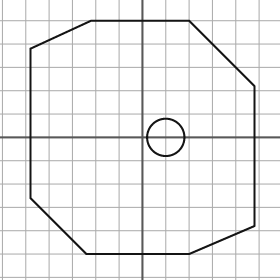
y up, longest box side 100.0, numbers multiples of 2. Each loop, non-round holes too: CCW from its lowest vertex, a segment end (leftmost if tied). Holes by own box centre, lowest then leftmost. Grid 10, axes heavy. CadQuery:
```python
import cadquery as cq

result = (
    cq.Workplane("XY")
    .moveTo(-24.0, -50.0)
    .lineTo(20.0, -50.0)
    .lineTo(48.0, -38.0)
    .lineTo(48.0, 22.0)
    .lineTo(20.0, 50.0)
    .lineTo(-22.0, 50.0)
    .lineTo(-48.0, 38.0)
    .lineTo(-48.0, -26.0)
    .close()
    .moveTo(10.0, 0.0)
    .circle(8.0)
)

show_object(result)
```